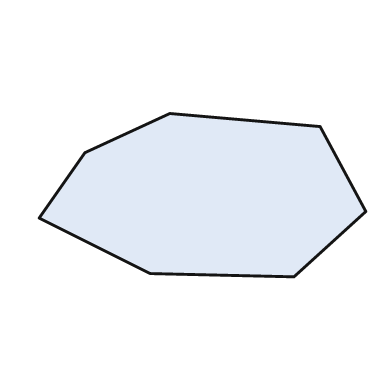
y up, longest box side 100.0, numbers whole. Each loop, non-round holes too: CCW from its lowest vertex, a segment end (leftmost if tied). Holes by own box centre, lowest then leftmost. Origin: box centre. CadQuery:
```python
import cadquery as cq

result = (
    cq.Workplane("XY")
    .moveTo(28.0, -25.0)
    .lineTo(50.0, -5.0)
    .lineTo(36.0, 21.0)
    .lineTo(-10.0, 25.0)
    .lineTo(-36.0, 13.0)
    .lineTo(-50.0, -7.0)
    .lineTo(-16.0, -24.0)
    .close()
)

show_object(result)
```